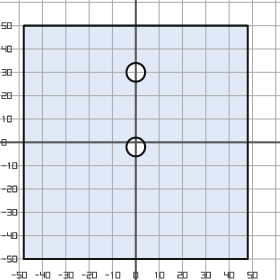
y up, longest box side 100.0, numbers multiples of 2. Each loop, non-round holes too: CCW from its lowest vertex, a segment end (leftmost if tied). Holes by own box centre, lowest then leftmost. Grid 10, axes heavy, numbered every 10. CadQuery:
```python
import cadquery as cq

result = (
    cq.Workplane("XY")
    .moveTo(-48.0, -50.0)
    .lineTo(48.0, -50.0)
    .lineTo(48.0, 50.0)
    .lineTo(-48.0, 50.0)
    .close()
    .moveTo(0.0, -2.0)
    .circle(4.0)
    .moveTo(0.0, 30.0)
    .circle(4.0)
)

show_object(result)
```